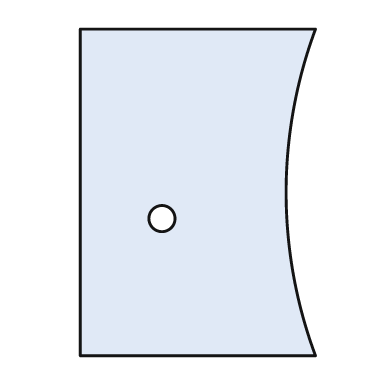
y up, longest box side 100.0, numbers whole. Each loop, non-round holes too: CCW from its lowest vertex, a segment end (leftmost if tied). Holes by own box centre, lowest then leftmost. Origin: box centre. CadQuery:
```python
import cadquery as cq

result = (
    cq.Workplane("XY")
    .moveTo(-36.0, -50.0)
    .lineTo(36.0, -50.0)
    .threePointArc((27.0, 0.0), (36.0, 50.0))
    .lineTo(-36.0, 50.0)
    .close()
    .moveTo(-11.0, -8.0)
    .circle(4.0)
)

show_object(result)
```